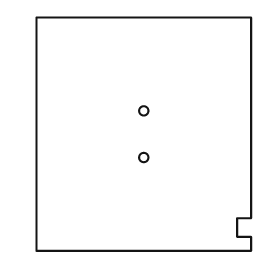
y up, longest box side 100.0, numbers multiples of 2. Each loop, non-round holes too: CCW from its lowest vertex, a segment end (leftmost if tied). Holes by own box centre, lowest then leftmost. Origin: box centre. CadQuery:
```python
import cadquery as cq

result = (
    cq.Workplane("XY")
    .moveTo(-46.0, -50.0)
    .lineTo(46.0, -50.0)
    .lineTo(46.0, -44.0)
    .lineTo(40.0, -44.0)
    .lineTo(40.0, -36.0)
    .lineTo(46.0, -36.0)
    .lineTo(46.0, 50.0)
    .lineTo(-46.0, 50.0)
    .close()
    .moveTo(0.0, -10.0)
    .circle(2.0)
    .moveTo(0.0, 10.0)
    .circle(2.0)
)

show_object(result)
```